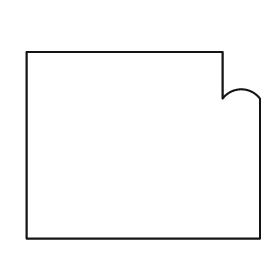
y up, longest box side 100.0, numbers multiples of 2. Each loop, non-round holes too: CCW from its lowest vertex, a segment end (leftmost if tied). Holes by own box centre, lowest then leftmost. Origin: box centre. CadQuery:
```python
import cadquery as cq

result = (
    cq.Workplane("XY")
    .moveTo(-50.0, -40.0)
    .lineTo(50.0, -40.0)
    .lineTo(50.0, 20.0)
    .threePointArc((42.0, 24.0), (34.0, 20.0))
    .lineTo(34.0, 40.0)
    .lineTo(-50.0, 40.0)
    .close()
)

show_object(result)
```